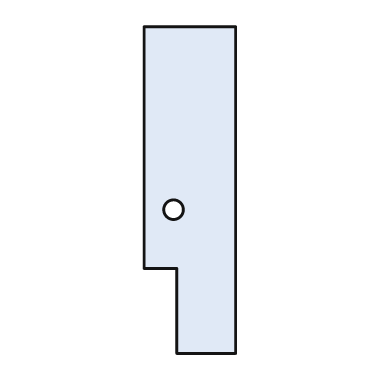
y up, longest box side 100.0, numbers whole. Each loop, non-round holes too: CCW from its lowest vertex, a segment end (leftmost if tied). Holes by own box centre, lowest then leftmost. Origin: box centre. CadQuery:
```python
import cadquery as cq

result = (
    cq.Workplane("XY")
    .moveTo(-4.0, -50.0)
    .lineTo(14.0, -50.0)
    .lineTo(14.0, 50.0)
    .lineTo(-14.0, 50.0)
    .lineTo(-14.0, -24.0)
    .lineTo(-4.0, -24.0)
    .close()
    .moveTo(-5.0, -6.0)
    .circle(3.0)
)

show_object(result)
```